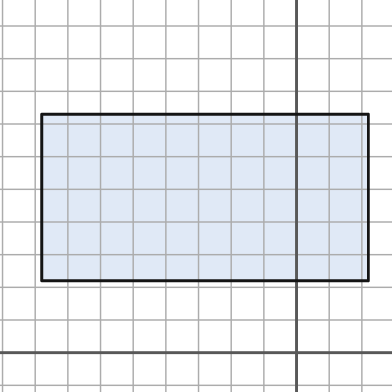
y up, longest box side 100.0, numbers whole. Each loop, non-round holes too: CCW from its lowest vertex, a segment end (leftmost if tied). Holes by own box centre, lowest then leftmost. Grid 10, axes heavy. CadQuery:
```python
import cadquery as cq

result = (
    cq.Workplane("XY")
    .moveTo(-78.0, 22.0)
    .lineTo(22.0, 22.0)
    .lineTo(22.0, 73.0)
    .lineTo(-78.0, 73.0)
    .close()
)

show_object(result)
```